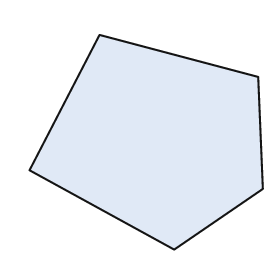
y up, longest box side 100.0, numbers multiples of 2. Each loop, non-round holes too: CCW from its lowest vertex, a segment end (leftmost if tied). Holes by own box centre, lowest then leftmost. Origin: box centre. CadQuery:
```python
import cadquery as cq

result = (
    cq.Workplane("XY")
    .moveTo(12.0, -46.0)
    .lineTo(50.0, -20.0)
    .lineTo(48.0, 28.0)
    .lineTo(-20.0, 46.0)
    .lineTo(-50.0, -12.0)
    .close()
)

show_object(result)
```